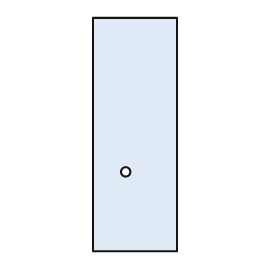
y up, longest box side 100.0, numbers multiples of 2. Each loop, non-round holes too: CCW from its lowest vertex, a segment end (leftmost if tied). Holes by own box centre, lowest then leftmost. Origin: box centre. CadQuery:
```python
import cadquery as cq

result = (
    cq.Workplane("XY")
    .moveTo(-18.0, -50.0)
    .lineTo(18.0, -50.0)
    .lineTo(18.0, 50.0)
    .lineTo(-18.0, 50.0)
    .close()
    .moveTo(-4.0, -16.0)
    .circle(2.0)
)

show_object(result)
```